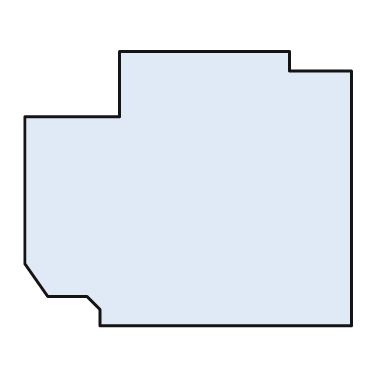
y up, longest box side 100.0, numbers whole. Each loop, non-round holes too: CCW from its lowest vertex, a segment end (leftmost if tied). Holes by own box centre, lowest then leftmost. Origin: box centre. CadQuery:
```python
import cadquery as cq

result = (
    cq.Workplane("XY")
    .moveTo(-27.0, -42.0)
    .lineTo(50.0, -42.0)
    .lineTo(50.0, 36.0)
    .lineTo(31.0, 36.0)
    .lineTo(31.0, 42.0)
    .lineTo(-21.0, 42.0)
    .lineTo(-21.0, 22.0)
    .lineTo(-50.0, 22.0)
    .lineTo(-50.0, -23.0)
    .lineTo(-43.0, -33.0)
    .lineTo(-31.0, -33.0)
    .lineTo(-27.0, -37.0)
    .close()
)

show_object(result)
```